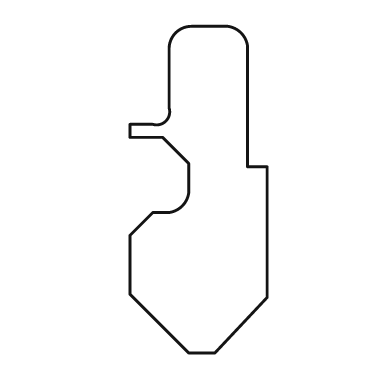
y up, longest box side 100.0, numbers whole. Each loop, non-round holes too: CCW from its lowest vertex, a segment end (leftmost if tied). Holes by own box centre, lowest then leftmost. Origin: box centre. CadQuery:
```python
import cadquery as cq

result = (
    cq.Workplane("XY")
    .moveTo(-3.0, -50.0)
    .lineTo(5.0, -50.0)
    .lineTo(21.0, -33.0)
    .lineTo(21.0, 7.0)
    .lineTo(15.0, 7.0)
    .lineTo(15.0, 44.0)
    .threePointArc((13.0, 48.0), (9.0, 50.0))
    .lineTo(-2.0, 50.0)
    .threePointArc((-7.0, 48.0), (-9.0, 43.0))
    .lineTo(-9.0, 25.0)
    .threePointArc((-10.0, 21.0), (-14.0, 20.0))
    .lineTo(-21.0, 20.0)
    .lineTo(-21.0, 16.0)
    .lineTo(-11.0, 16.0)
    .lineTo(-3.0, 8.0)
    .lineTo(-3.0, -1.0)
    .threePointArc((-5.0, -5.0), (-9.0, -7.0))
    .lineTo(-14.0, -7.0)
    .lineTo(-21.0, -14.0)
    .lineTo(-21.0, -32.0)
    .close()
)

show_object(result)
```